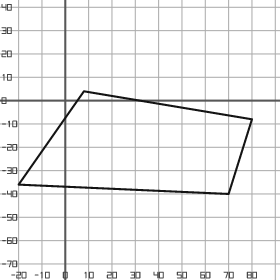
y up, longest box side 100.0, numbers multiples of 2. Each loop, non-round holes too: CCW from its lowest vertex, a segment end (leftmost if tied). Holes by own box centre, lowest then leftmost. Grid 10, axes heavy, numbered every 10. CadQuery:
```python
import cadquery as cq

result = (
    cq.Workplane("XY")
    .moveTo(70.0, -40.0)
    .lineTo(80.0, -8.0)
    .lineTo(8.0, 4.0)
    .lineTo(-20.0, -36.0)
    .close()
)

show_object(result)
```